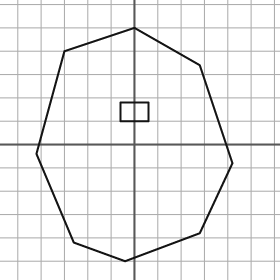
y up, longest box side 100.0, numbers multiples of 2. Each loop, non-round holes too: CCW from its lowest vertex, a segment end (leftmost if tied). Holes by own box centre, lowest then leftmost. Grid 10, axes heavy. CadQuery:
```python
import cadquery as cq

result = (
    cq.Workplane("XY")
    .moveTo(-4.0, -50.0)
    .lineTo(28.0, -38.0)
    .lineTo(42.0, -8.0)
    .lineTo(28.0, 34.0)
    .lineTo(0.0, 50.0)
    .lineTo(-30.0, 40.0)
    .lineTo(-42.0, -4.0)
    .lineTo(-26.0, -42.0)
    .close()
    .moveTo(-6.0, 10.0)
    .lineTo(6.0, 10.0)
    .lineTo(6.0, 18.0)
    .lineTo(-6.0, 18.0)
    .close()
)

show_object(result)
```